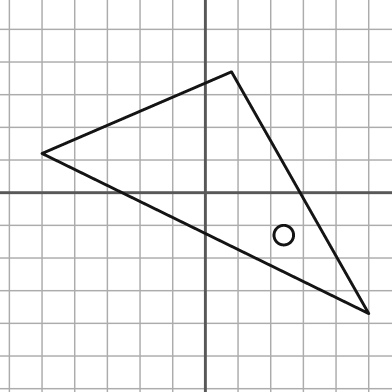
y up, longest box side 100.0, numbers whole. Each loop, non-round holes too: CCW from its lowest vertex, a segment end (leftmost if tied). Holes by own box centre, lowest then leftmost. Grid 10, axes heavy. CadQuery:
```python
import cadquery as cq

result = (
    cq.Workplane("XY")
    .moveTo(50.0, -37.0)
    .lineTo(8.0, 37.0)
    .lineTo(-50.0, 12.0)
    .close()
    .moveTo(24.0, -13.0)
    .circle(3.0)
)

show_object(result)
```